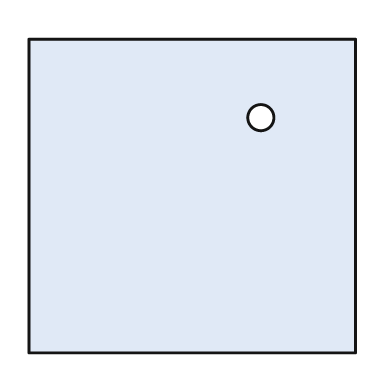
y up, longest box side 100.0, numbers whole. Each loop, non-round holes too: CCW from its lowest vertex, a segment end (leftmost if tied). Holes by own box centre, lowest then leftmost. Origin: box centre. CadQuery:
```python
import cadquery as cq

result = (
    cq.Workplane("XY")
    .moveTo(-50.0, -48.0)
    .lineTo(50.0, -48.0)
    .lineTo(50.0, 48.0)
    .lineTo(-50.0, 48.0)
    .close()
    .moveTo(21.0, 24.0)
    .circle(4.0)
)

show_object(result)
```